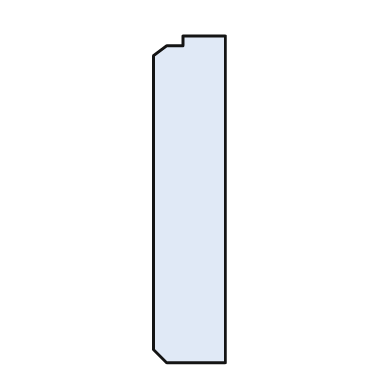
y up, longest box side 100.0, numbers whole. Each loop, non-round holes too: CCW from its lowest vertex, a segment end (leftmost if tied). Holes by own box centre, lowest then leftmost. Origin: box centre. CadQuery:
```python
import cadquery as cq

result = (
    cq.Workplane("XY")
    .moveTo(-7.0, -50.0)
    .lineTo(11.0, -50.0)
    .lineTo(11.0, 50.0)
    .lineTo(-2.0, 50.0)
    .lineTo(-2.0, 47.0)
    .lineTo(-7.0, 47.0)
    .lineTo(-11.0, 44.0)
    .lineTo(-11.0, -46.0)
    .close()
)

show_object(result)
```